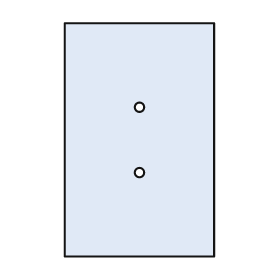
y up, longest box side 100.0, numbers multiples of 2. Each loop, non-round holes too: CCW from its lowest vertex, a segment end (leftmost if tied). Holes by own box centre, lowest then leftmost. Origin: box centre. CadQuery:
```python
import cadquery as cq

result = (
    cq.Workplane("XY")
    .moveTo(-32.0, -50.0)
    .lineTo(32.0, -50.0)
    .lineTo(32.0, 50.0)
    .lineTo(-32.0, 50.0)
    .close()
    .moveTo(0.0, -14.0)
    .circle(2.0)
    .moveTo(0.0, 14.0)
    .circle(2.0)
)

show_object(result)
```